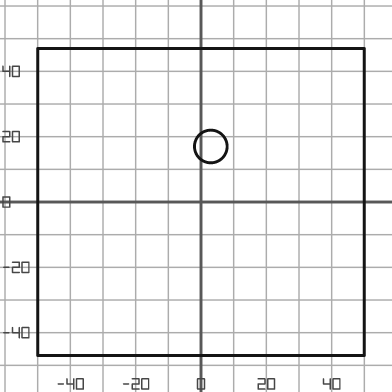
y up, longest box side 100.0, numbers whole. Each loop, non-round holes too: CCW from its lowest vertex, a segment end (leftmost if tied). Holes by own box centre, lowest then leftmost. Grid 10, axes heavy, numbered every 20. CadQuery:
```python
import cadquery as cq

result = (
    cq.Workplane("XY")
    .moveTo(-50.0, -47.0)
    .lineTo(50.0, -47.0)
    .lineTo(50.0, 47.0)
    .lineTo(-50.0, 47.0)
    .close()
    .moveTo(3.0, 17.0)
    .circle(5.0)
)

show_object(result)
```